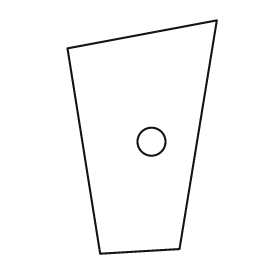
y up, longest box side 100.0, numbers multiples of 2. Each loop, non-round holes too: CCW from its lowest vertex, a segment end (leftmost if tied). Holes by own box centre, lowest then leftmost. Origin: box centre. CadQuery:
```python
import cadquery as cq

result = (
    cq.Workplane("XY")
    .moveTo(-18.0, -50.0)
    .lineTo(16.0, -48.0)
    .lineTo(32.0, 50.0)
    .lineTo(-32.0, 38.0)
    .close()
    .moveTo(4.0, -2.0)
    .circle(6.0)
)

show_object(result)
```